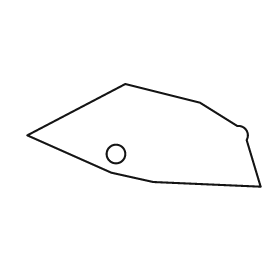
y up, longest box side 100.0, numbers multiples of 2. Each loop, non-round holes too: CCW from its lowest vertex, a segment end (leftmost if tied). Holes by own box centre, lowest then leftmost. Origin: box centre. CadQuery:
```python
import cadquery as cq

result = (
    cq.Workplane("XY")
    .moveTo(50.0, -22.0)
    .lineTo(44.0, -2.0)
    .threePointArc((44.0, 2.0), (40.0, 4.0))
    .lineTo(24.0, 14.0)
    .lineTo(-8.0, 22.0)
    .lineTo(-50.0, 0.0)
    .lineTo(-14.0, -16.0)
    .lineTo(4.0, -20.0)
    .close()
    .moveTo(-12.0, -8.0)
    .circle(4.0)
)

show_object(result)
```